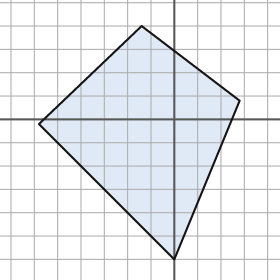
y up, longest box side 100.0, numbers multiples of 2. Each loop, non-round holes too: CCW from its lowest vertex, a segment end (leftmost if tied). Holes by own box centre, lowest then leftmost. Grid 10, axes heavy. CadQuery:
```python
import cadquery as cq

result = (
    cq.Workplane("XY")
    .moveTo(0.0, -60.0)
    .lineTo(28.0, 8.0)
    .lineTo(-14.0, 40.0)
    .lineTo(-58.0, -2.0)
    .close()
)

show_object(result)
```